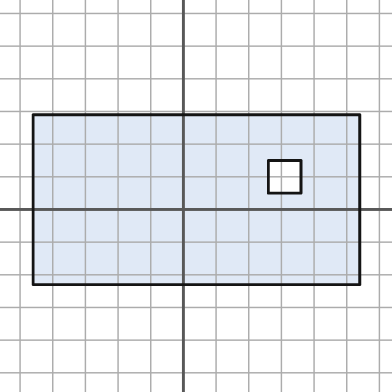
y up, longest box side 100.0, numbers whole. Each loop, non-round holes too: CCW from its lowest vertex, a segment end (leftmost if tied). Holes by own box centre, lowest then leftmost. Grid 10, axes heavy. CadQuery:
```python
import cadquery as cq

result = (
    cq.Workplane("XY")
    .moveTo(-46.0, -23.0)
    .lineTo(54.0, -23.0)
    .lineTo(54.0, 29.0)
    .lineTo(-46.0, 29.0)
    .close()
    .moveTo(26.0, 5.0)
    .lineTo(36.0, 5.0)
    .lineTo(36.0, 15.0)
    .lineTo(26.0, 15.0)
    .close()
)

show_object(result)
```